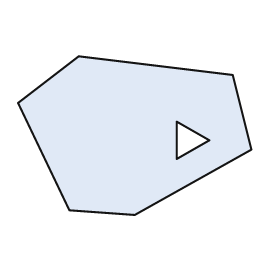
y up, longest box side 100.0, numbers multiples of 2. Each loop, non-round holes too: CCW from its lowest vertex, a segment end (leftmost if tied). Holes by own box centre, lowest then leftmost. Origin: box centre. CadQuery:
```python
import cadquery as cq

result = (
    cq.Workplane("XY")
    .moveTo(0.0, -34.0)
    .lineTo(50.0, -6.0)
    .lineTo(42.0, 26.0)
    .lineTo(-24.0, 34.0)
    .lineTo(-50.0, 14.0)
    .lineTo(-28.0, -32.0)
    .close()
    .moveTo(18.0, -10.0)
    .lineTo(32.0, -2.0)
    .lineTo(18.0, 6.0)
    .close()
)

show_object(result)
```